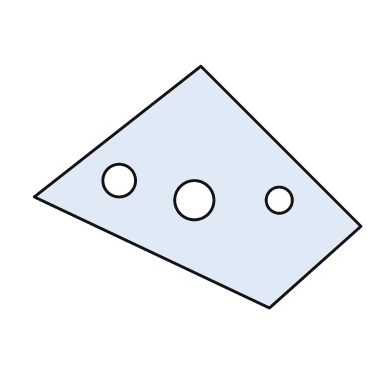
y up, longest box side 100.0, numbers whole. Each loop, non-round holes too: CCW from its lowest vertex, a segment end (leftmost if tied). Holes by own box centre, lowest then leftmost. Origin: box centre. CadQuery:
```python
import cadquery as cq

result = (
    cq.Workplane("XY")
    .moveTo(22.0, -37.0)
    .lineTo(50.0, -12.0)
    .lineTo(1.0, 37.0)
    .lineTo(-50.0, -3.0)
    .close()
    .moveTo(-1.0, -4.0)
    .circle(6.0)
    .moveTo(25.0, -4.0)
    .circle(4.0)
    .moveTo(-24.0, 2.0)
    .circle(5.0)
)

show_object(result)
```